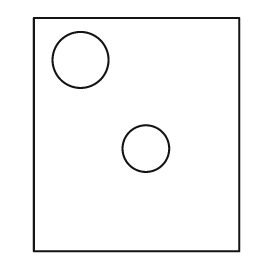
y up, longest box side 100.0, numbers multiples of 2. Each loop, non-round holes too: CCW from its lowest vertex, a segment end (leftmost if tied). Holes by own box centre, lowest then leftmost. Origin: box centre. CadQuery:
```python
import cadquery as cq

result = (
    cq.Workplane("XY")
    .moveTo(-44.0, -50.0)
    .lineTo(44.0, -50.0)
    .lineTo(44.0, 50.0)
    .lineTo(-44.0, 50.0)
    .close()
    .moveTo(4.0, -6.0)
    .circle(10.0)
    .moveTo(-24.0, 32.0)
    .circle(12.0)
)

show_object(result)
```